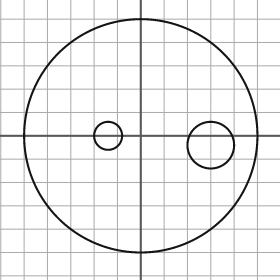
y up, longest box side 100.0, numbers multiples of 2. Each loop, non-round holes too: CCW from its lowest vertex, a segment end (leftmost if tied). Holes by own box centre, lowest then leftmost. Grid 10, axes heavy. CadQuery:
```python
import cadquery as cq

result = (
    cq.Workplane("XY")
    .moveTo(0.0, 0.0)
    .circle(50.0)
    .moveTo(30.0, -4.0)
    .circle(10.0)
    .moveTo(-14.0, 0.0)
    .circle(6.0)
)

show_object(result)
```